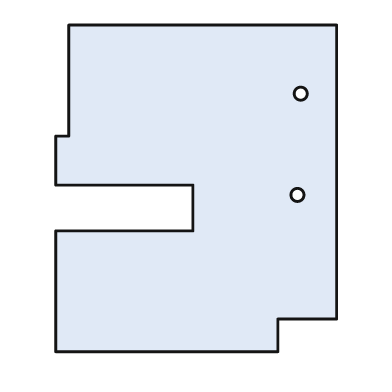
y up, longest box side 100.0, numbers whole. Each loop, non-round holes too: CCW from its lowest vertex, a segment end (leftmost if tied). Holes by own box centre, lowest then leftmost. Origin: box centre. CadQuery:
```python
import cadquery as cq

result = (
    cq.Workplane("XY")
    .moveTo(-43.0, -50.0)
    .lineTo(25.0, -50.0)
    .lineTo(25.0, -40.0)
    .lineTo(43.0, -40.0)
    .lineTo(43.0, 50.0)
    .lineTo(-39.0, 50.0)
    .lineTo(-39.0, 16.0)
    .lineTo(-43.0, 16.0)
    .lineTo(-43.0, 1.0)
    .lineTo(-1.0, 1.0)
    .lineTo(-1.0, -13.0)
    .lineTo(-43.0, -13.0)
    .close()
    .moveTo(31.0, -2.0)
    .circle(2.0)
    .moveTo(32.0, 29.0)
    .circle(2.0)
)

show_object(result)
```